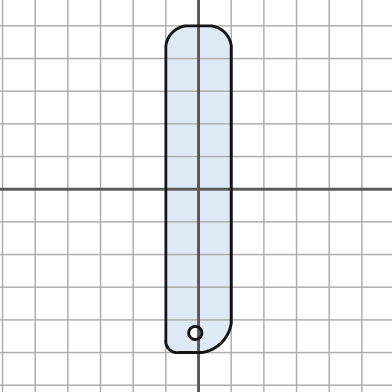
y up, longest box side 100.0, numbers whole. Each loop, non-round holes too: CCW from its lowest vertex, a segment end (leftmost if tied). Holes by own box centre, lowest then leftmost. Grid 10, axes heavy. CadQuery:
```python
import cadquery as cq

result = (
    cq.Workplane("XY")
    .moveTo(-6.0, -50.0)
    .lineTo(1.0, -50.0)
    .threePointArc((7.0, -47.0), (10.0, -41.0))
    .lineTo(10.0, 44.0)
    .threePointArc((8.0, 48.0), (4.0, 50.0))
    .lineTo(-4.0, 50.0)
    .threePointArc((-8.0, 48.0), (-10.0, 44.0))
    .lineTo(-10.0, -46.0)
    .threePointArc((-9.0, -49.0), (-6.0, -50.0))
    .close()
    .moveTo(-1.0, -44.0)
    .circle(2.0)
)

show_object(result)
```